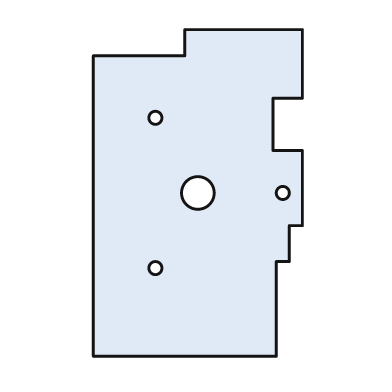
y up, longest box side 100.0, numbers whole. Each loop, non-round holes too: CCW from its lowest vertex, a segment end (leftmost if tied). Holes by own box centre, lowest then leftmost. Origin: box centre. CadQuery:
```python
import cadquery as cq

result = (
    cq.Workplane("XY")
    .moveTo(-32.0, -50.0)
    .lineTo(24.0, -50.0)
    .lineTo(24.0, -21.0)
    .lineTo(28.0, -21.0)
    .lineTo(28.0, -10.0)
    .lineTo(32.0, -10.0)
    .lineTo(32.0, 13.0)
    .lineTo(23.0, 13.0)
    .lineTo(23.0, 29.0)
    .lineTo(32.0, 29.0)
    .lineTo(32.0, 50.0)
    .lineTo(-4.0, 50.0)
    .lineTo(-4.0, 42.0)
    .lineTo(-32.0, 42.0)
    .close()
    .moveTo(-13.0, -23.0)
    .circle(2.0)
    .moveTo(0.0, 0.0)
    .circle(5.0)
    .moveTo(26.0, 0.0)
    .circle(2.0)
    .moveTo(-13.0, 23.0)
    .circle(2.0)
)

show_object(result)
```